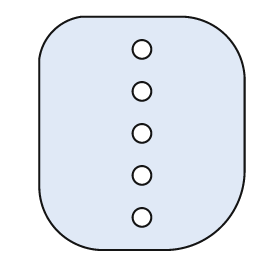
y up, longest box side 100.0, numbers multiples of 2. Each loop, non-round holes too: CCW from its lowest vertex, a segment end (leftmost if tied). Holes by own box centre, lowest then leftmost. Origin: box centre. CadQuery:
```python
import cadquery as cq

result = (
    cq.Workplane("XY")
    .moveTo(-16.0, -50.0)
    .lineTo(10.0, -50.0)
    .threePointArc((34.0, -40.0), (44.0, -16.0))
    .lineTo(44.0, 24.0)
    .threePointArc((36.0, 42.0), (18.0, 50.0))
    .lineTo(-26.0, 50.0)
    .threePointArc((-38.0, 44.0), (-44.0, 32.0))
    .lineTo(-44.0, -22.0)
    .threePointArc((-36.0, -42.0), (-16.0, -50.0))
    .close()
    .moveTo(0.0, -36.0)
    .circle(4.0)
    .moveTo(0.0, -18.0)
    .circle(4.0)
    .moveTo(0.0, 0.0)
    .circle(4.0)
    .moveTo(0.0, 18.0)
    .circle(4.0)
    .moveTo(0.0, 36.0)
    .circle(4.0)
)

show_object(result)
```